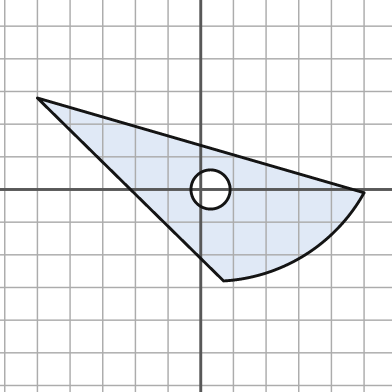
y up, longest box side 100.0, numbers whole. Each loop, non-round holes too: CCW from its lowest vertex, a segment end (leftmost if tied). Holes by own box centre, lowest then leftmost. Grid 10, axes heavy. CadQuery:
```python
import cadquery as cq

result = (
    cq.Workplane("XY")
    .moveTo(7.0, -28.0)
    .threePointArc((32.0, -20.0), (50.0, -1.0))
    .lineTo(-50.0, 28.0)
    .close()
    .moveTo(3.0, 0.0)
    .circle(6.0)
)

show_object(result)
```